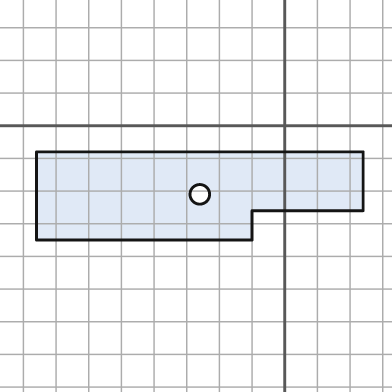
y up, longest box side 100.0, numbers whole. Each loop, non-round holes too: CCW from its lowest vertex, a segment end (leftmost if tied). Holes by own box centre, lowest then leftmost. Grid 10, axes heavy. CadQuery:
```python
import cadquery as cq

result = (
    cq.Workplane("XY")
    .moveTo(-76.0, -35.0)
    .lineTo(-10.0, -35.0)
    .lineTo(-10.0, -26.0)
    .lineTo(24.0, -26.0)
    .lineTo(24.0, -8.0)
    .lineTo(-76.0, -8.0)
    .close()
    .moveTo(-26.0, -21.0)
    .circle(3.0)
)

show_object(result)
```